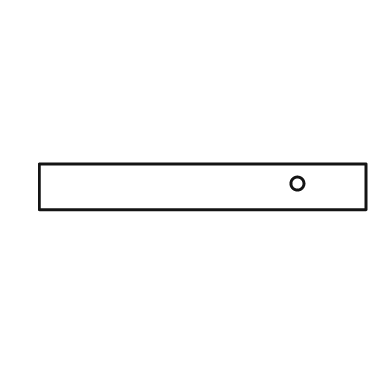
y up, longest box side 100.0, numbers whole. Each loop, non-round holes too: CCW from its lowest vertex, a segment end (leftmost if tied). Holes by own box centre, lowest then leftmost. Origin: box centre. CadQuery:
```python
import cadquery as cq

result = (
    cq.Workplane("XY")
    .moveTo(-50.0, -7.0)
    .lineTo(50.0, -7.0)
    .lineTo(50.0, 7.0)
    .lineTo(-50.0, 7.0)
    .close()
    .moveTo(29.0, 1.0)
    .circle(2.0)
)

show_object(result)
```